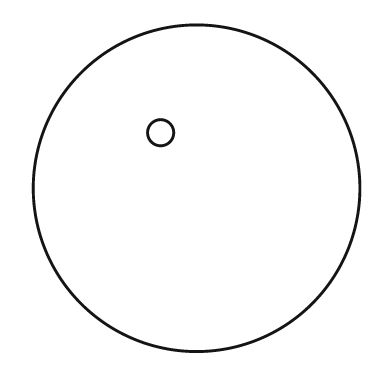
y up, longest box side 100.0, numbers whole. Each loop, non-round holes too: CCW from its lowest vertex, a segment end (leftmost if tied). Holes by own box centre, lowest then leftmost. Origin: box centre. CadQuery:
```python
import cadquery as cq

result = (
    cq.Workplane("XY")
    .moveTo(0.0, 0.0)
    .circle(50.0)
    .moveTo(-11.0, 17.0)
    .circle(4.0)
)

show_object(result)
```